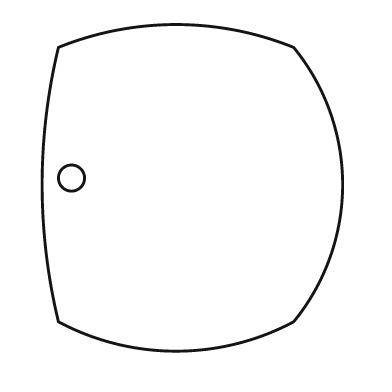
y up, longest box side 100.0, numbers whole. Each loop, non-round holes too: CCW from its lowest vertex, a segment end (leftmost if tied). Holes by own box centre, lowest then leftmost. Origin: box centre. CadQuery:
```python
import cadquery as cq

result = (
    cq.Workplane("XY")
    .moveTo(-41.0, -41.0)
    .threePointArc((-5.0, -50.0), (31.0, -41.0))
    .threePointArc((46.0, 1.0), (31.0, 43.0))
    .threePointArc((-5.0, 50.0), (-41.0, 43.0))
    .threePointArc((-46.0, 1.0), (-41.0, -41.0))
    .close()
    .moveTo(-37.0, 3.0)
    .circle(4.0)
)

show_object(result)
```